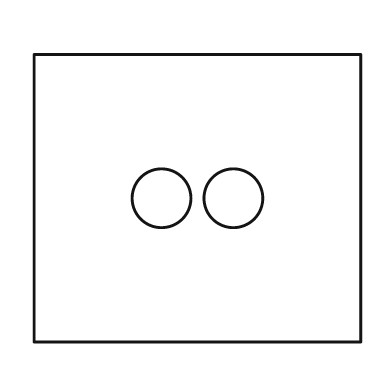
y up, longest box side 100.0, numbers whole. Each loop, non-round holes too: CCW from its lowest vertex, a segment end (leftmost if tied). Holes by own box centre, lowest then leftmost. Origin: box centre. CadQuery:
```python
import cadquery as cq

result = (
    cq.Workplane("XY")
    .moveTo(-50.0, -44.0)
    .lineTo(50.0, -44.0)
    .lineTo(50.0, 44.0)
    .lineTo(-50.0, 44.0)
    .close()
    .moveTo(-11.0, 0.0)
    .circle(9.0)
    .moveTo(11.0, 0.0)
    .circle(9.0)
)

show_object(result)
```